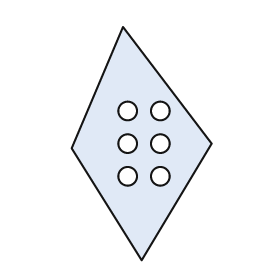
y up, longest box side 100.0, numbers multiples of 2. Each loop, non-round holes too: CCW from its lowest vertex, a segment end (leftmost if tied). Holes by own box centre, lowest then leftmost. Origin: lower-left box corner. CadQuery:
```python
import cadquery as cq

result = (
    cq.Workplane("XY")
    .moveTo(30.0, 0.0)
    .lineTo(60.0, 50.0)
    .lineTo(22.0, 100.0)
    .lineTo(0.0, 48.0)
    .close()
    .moveTo(24.0, 36.0)
    .circle(4.0)
    .moveTo(38.0, 36.0)
    .circle(4.0)
    .moveTo(24.0, 50.0)
    .circle(4.0)
    .moveTo(38.0, 50.0)
    .circle(4.0)
    .moveTo(24.0, 64.0)
    .circle(4.0)
    .moveTo(38.0, 64.0)
    .circle(4.0)
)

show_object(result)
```